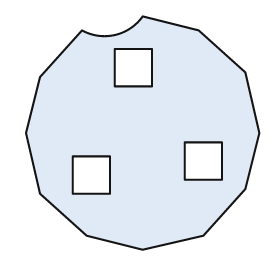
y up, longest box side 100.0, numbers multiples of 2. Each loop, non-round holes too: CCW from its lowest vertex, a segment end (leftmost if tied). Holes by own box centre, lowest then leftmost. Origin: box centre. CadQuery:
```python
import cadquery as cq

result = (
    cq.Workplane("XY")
    .moveTo(0.0, -50.0)
    .lineTo(26.0, -44.0)
    .lineTo(44.0, -24.0)
    .lineTo(50.0, 0.0)
    .lineTo(44.0, 26.0)
    .lineTo(24.0, 44.0)
    .lineTo(0.0, 50.0)
    .threePointArc((-12.0, 42.0), (-26.0, 44.0))
    .lineTo(-44.0, 24.0)
    .lineTo(-50.0, 0.0)
    .lineTo(-44.0, -26.0)
    .lineTo(-24.0, -44.0)
    .close()
    .moveTo(-30.0, -26.0)
    .lineTo(-14.0, -26.0)
    .lineTo(-14.0, -10.0)
    .lineTo(-30.0, -10.0)
    .close()
    .moveTo(18.0, -20.0)
    .lineTo(34.0, -20.0)
    .lineTo(34.0, -4.0)
    .lineTo(18.0, -4.0)
    .close()
    .moveTo(-12.0, 20.0)
    .lineTo(4.0, 20.0)
    .lineTo(4.0, 36.0)
    .lineTo(-12.0, 36.0)
    .close()
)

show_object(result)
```